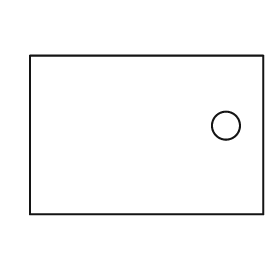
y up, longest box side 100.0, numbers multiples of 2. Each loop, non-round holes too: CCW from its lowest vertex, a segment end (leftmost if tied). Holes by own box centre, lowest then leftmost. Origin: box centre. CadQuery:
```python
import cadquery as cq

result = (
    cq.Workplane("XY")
    .moveTo(-50.0, -34.0)
    .lineTo(50.0, -34.0)
    .lineTo(50.0, 34.0)
    .lineTo(-50.0, 34.0)
    .close()
    .moveTo(34.0, 4.0)
    .circle(6.0)
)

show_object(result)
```